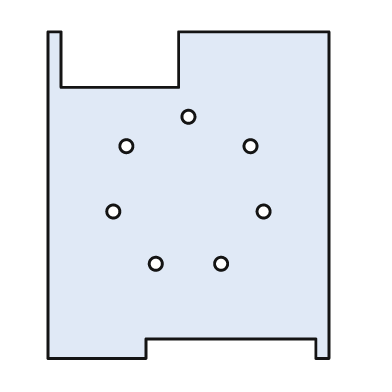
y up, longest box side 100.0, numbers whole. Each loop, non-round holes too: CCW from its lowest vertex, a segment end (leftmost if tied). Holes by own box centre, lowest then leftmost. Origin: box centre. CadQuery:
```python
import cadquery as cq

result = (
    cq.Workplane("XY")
    .moveTo(-43.0, -50.0)
    .lineTo(-13.0, -50.0)
    .lineTo(-13.0, -44.0)
    .lineTo(39.0, -44.0)
    .lineTo(39.0, -50.0)
    .lineTo(43.0, -50.0)
    .lineTo(43.0, 50.0)
    .lineTo(-3.0, 50.0)
    .lineTo(-3.0, 33.0)
    .lineTo(-39.0, 33.0)
    .lineTo(-39.0, 50.0)
    .lineTo(-43.0, 50.0)
    .close()
    .moveTo(-10.0, -21.0)
    .circle(2.0)
    .moveTo(10.0, -21.0)
    .circle(2.0)
    .moveTo(-23.0, -5.0)
    .circle(2.0)
    .moveTo(23.0, -5.0)
    .circle(2.0)
    .moveTo(-19.0, 15.0)
    .circle(2.0)
    .moveTo(19.0, 15.0)
    .circle(2.0)
    .moveTo(0.0, 24.0)
    .circle(2.0)
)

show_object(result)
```